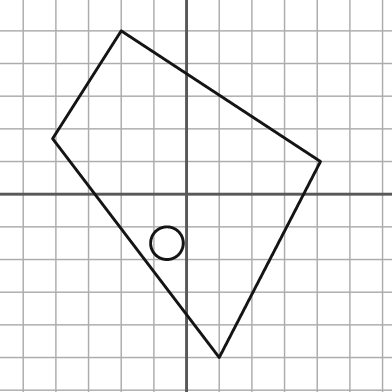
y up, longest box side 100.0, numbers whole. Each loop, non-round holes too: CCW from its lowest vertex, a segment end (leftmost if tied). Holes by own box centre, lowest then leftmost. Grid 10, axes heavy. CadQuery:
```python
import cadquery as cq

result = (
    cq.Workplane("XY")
    .moveTo(10.0, -50.0)
    .lineTo(41.0, 10.0)
    .lineTo(-20.0, 50.0)
    .lineTo(-41.0, 17.0)
    .close()
    .moveTo(-6.0, -15.0)
    .circle(5.0)
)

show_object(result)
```